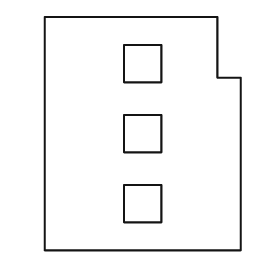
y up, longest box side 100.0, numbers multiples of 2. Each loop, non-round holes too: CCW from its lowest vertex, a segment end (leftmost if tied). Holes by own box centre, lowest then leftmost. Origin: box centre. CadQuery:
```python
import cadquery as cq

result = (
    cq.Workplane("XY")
    .moveTo(-42.0, -50.0)
    .lineTo(42.0, -50.0)
    .lineTo(42.0, 24.0)
    .lineTo(32.0, 24.0)
    .lineTo(32.0, 50.0)
    .lineTo(-42.0, 50.0)
    .close()
    .moveTo(-8.0, -38.0)
    .lineTo(8.0, -38.0)
    .lineTo(8.0, -22.0)
    .lineTo(-8.0, -22.0)
    .close()
    .moveTo(-8.0, -8.0)
    .lineTo(8.0, -8.0)
    .lineTo(8.0, 8.0)
    .lineTo(-8.0, 8.0)
    .close()
    .moveTo(-8.0, 22.0)
    .lineTo(8.0, 22.0)
    .lineTo(8.0, 38.0)
    .lineTo(-8.0, 38.0)
    .close()
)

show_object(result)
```